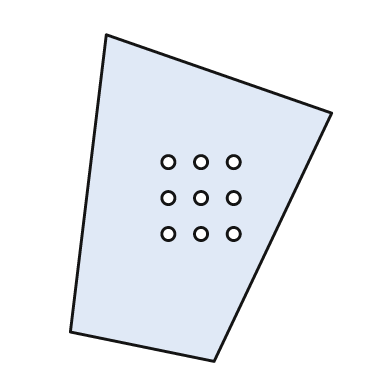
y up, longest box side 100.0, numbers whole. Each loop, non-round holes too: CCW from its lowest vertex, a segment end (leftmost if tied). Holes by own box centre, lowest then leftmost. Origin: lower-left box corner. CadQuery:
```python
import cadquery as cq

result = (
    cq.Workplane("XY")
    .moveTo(44.0, 0.0)
    .lineTo(80.0, 76.0)
    .lineTo(11.0, 100.0)
    .lineTo(0.0, 9.0)
    .close()
    .moveTo(30.0, 39.0)
    .circle(2.0)
    .moveTo(40.0, 39.0)
    .circle(2.0)
    .moveTo(50.0, 39.0)
    .circle(2.0)
    .moveTo(30.0, 50.0)
    .circle(2.0)
    .moveTo(40.0, 50.0)
    .circle(2.0)
    .moveTo(50.0, 50.0)
    .circle(2.0)
    .moveTo(30.0, 61.0)
    .circle(2.0)
    .moveTo(40.0, 61.0)
    .circle(2.0)
    .moveTo(50.0, 61.0)
    .circle(2.0)
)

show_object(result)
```